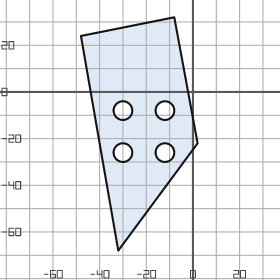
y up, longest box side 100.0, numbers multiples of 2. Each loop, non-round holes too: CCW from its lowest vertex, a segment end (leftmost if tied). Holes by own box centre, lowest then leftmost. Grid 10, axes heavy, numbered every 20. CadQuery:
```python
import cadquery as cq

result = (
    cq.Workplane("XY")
    .moveTo(-32.0, -68.0)
    .lineTo(2.0, -22.0)
    .lineTo(-8.0, 32.0)
    .lineTo(-48.0, 24.0)
    .close()
    .moveTo(-30.0, -26.0)
    .circle(4.0)
    .moveTo(-12.0, -26.0)
    .circle(4.0)
    .moveTo(-30.0, -8.0)
    .circle(4.0)
    .moveTo(-12.0, -8.0)
    .circle(4.0)
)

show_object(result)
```